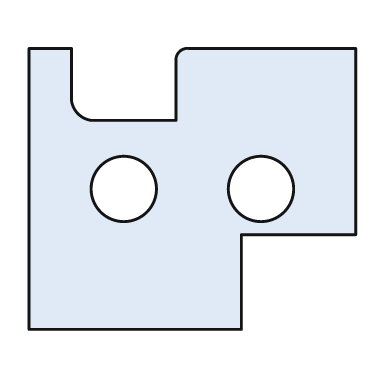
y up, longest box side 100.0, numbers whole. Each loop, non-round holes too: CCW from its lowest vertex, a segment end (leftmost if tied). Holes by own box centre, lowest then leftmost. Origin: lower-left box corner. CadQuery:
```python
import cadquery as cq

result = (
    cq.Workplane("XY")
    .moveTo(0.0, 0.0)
    .lineTo(65.0, 0.0)
    .lineTo(65.0, 29.0)
    .lineTo(100.0, 29.0)
    .lineTo(100.0, 86.0)
    .lineTo(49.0, 86.0)
    .threePointArc((46.0, 85.0), (45.0, 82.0))
    .lineTo(45.0, 64.0)
    .lineTo(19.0, 64.0)
    .threePointArc((15.0, 66.0), (13.0, 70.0))
    .lineTo(13.0, 86.0)
    .lineTo(0.0, 86.0)
    .close()
    .moveTo(29.0, 43.0)
    .circle(10.0)
    .moveTo(71.0, 43.0)
    .circle(10.0)
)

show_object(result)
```